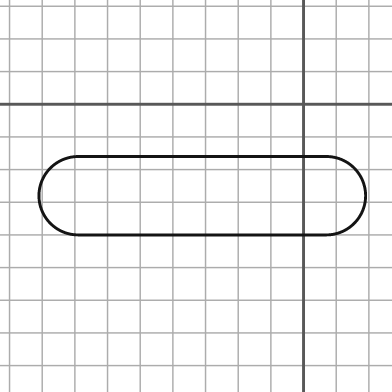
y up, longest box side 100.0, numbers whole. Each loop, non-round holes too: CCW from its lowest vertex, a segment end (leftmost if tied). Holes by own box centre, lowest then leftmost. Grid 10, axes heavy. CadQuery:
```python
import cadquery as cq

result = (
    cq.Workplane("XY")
    .moveTo(-69.0, -40.0)
    .lineTo(7.0, -40.0)
    .threePointArc((19.0, -28.0), (7.0, -16.0))
    .lineTo(-69.0, -16.0)
    .threePointArc((-81.0, -28.0), (-69.0, -40.0))
    .close()
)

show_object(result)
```